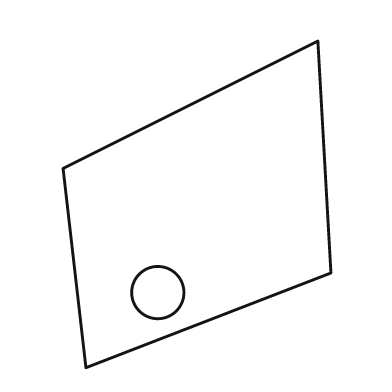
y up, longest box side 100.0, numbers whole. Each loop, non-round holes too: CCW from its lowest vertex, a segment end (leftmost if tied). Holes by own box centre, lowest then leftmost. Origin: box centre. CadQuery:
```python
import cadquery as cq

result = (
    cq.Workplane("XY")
    .moveTo(-34.0, -50.0)
    .lineTo(41.0, -21.0)
    .lineTo(37.0, 50.0)
    .lineTo(-41.0, 11.0)
    .close()
    .moveTo(-12.0, -27.0)
    .circle(8.0)
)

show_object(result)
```